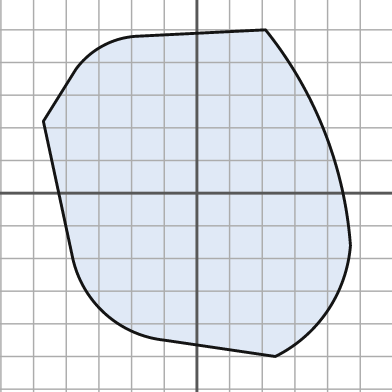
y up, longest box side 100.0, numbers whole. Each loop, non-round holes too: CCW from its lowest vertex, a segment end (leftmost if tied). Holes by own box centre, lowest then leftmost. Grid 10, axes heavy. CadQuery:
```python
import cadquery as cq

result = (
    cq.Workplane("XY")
    .moveTo(24.0, -50.0)
    .threePointArc((40.0, -36.0), (47.0, -16.0))
    .threePointArc((39.0, 19.0), (21.0, 50.0))
    .lineTo(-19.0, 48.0)
    .threePointArc((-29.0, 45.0), (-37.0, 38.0))
    .lineTo(-47.0, 22.0)
    .lineTo(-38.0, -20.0)
    .threePointArc((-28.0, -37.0), (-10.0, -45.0))
    .close()
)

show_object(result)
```